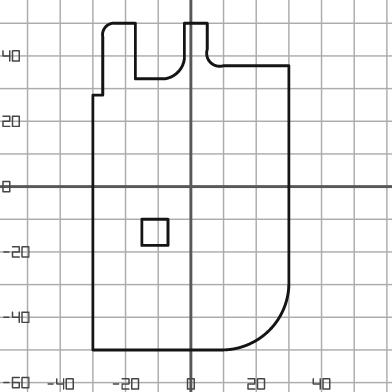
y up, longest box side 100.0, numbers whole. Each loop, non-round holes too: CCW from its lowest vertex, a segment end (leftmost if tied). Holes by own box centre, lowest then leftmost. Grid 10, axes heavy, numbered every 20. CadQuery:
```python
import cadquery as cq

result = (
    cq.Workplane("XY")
    .moveTo(-30.0, -50.0)
    .lineTo(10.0, -50.0)
    .threePointArc((24.0, -44.0), (30.0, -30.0))
    .lineTo(30.0, 37.0)
    .lineTo(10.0, 37.0)
    .threePointArc((6.0, 38.0), (5.0, 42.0))
    .lineTo(5.0, 50.0)
    .lineTo(-2.0, 50.0)
    .lineTo(-2.0, 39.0)
    .threePointArc((-4.0, 35.0), (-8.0, 33.0))
    .lineTo(-17.0, 33.0)
    .lineTo(-17.0, 50.0)
    .lineTo(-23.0, 50.0)
    .threePointArc((-26.0, 49.0), (-27.0, 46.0))
    .lineTo(-27.0, 28.0)
    .lineTo(-30.0, 28.0)
    .close()
    .moveTo(-15.0, -18.0)
    .lineTo(-7.0, -18.0)
    .lineTo(-7.0, -10.0)
    .lineTo(-15.0, -10.0)
    .close()
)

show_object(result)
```